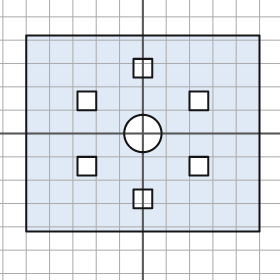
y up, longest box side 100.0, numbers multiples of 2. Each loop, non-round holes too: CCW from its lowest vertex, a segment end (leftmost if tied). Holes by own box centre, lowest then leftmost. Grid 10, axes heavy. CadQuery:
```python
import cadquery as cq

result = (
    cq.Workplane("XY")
    .moveTo(-50.0, -42.0)
    .lineTo(50.0, -42.0)
    .lineTo(50.0, 42.0)
    .lineTo(-50.0, 42.0)
    .close()
    .moveTo(-4.0, -32.0)
    .lineTo(4.0, -32.0)
    .lineTo(4.0, -24.0)
    .lineTo(-4.0, -24.0)
    .close()
    .moveTo(-28.0, -18.0)
    .lineTo(-20.0, -18.0)
    .lineTo(-20.0, -10.0)
    .lineTo(-28.0, -10.0)
    .close()
    .moveTo(20.0, -18.0)
    .lineTo(28.0, -18.0)
    .lineTo(28.0, -10.0)
    .lineTo(20.0, -10.0)
    .close()
    .moveTo(0.0, 0.0)
    .circle(8.0)
    .moveTo(-28.0, 10.0)
    .lineTo(-20.0, 10.0)
    .lineTo(-20.0, 18.0)
    .lineTo(-28.0, 18.0)
    .close()
    .moveTo(20.0, 10.0)
    .lineTo(28.0, 10.0)
    .lineTo(28.0, 18.0)
    .lineTo(20.0, 18.0)
    .close()
    .moveTo(-4.0, 24.0)
    .lineTo(4.0, 24.0)
    .lineTo(4.0, 32.0)
    .lineTo(-4.0, 32.0)
    .close()
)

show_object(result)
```